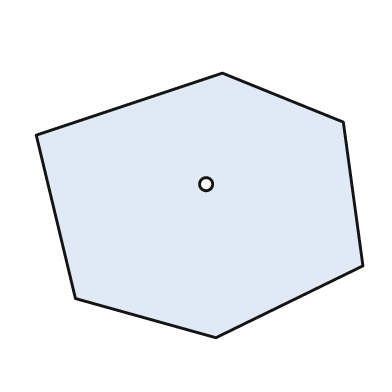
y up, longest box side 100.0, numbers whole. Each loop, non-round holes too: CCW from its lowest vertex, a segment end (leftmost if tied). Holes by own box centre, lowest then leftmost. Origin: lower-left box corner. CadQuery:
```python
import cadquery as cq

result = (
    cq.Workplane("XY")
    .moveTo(55.0, 0.0)
    .lineTo(100.0, 22.0)
    .lineTo(94.0, 66.0)
    .lineTo(57.0, 81.0)
    .lineTo(0.0, 62.0)
    .lineTo(12.0, 12.0)
    .close()
    .moveTo(52.0, 47.0)
    .circle(2.0)
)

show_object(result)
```